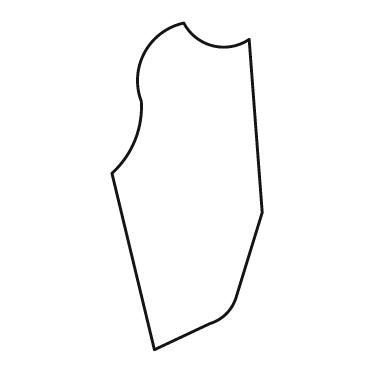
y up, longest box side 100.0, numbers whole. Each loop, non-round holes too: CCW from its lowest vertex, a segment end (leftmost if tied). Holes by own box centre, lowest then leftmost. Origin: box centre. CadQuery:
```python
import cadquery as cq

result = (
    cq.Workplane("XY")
    .moveTo(-10.0, -50.0)
    .lineTo(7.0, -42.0)
    .threePointArc((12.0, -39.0), (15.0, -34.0))
    .lineTo(23.0, -8.0)
    .lineTo(19.0, 45.0)
    .threePointArc((8.0, 43.0), (-1.0, 50.0))
    .threePointArc((-13.0, 41.0), (-14.0, 26.0))
    .threePointArc((-16.0, 14.0), (-23.0, 4.0))
    .close()
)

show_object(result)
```